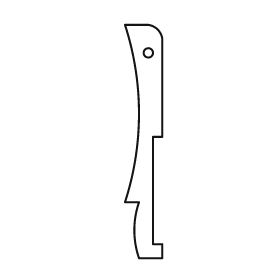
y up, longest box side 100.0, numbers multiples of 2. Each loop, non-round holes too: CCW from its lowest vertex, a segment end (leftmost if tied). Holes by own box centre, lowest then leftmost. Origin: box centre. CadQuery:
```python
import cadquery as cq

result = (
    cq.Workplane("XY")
    .moveTo(-2.0, -50.0)
    .lineTo(8.0, -50.0)
    .lineTo(8.0, -44.0)
    .lineTo(4.0, -44.0)
    .lineTo(4.0, 2.0)
    .lineTo(8.0, 2.0)
    .lineTo(8.0, 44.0)
    .threePointArc((6.0, 48.0), (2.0, 50.0))
    .lineTo(-8.0, 50.0)
    .threePointArc((-2.0, 12.0), (-8.0, -26.0))
    .lineTo(-2.0, -26.0)
    .threePointArc((-4.0, -38.0), (-2.0, -50.0))
    .close()
    .moveTo(2.0, 38.0)
    .circle(2.0)
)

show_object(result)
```